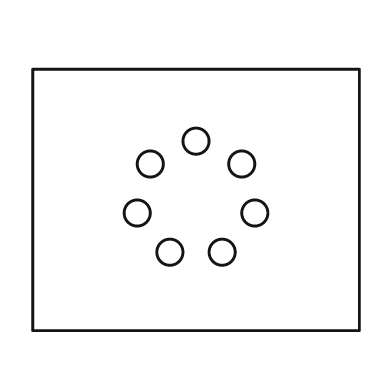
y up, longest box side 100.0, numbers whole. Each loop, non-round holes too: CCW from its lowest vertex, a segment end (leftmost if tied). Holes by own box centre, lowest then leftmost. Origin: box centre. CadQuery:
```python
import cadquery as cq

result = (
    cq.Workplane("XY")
    .moveTo(-50.0, -40.0)
    .lineTo(50.0, -40.0)
    .lineTo(50.0, 40.0)
    .lineTo(-50.0, 40.0)
    .close()
    .moveTo(-8.0, -16.0)
    .circle(4.0)
    .moveTo(8.0, -16.0)
    .circle(4.0)
    .moveTo(-18.0, -4.0)
    .circle(4.0)
    .moveTo(18.0, -4.0)
    .circle(4.0)
    .moveTo(-14.0, 11.0)
    .circle(4.0)
    .moveTo(14.0, 11.0)
    .circle(4.0)
    .moveTo(0.0, 18.0)
    .circle(4.0)
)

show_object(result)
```